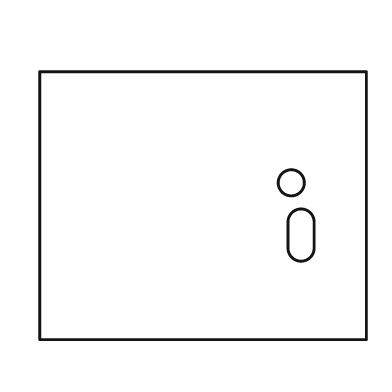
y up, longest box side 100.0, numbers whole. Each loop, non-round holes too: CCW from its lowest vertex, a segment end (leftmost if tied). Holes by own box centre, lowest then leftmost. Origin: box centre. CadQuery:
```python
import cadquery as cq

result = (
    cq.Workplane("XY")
    .moveTo(-50.0, -41.0)
    .lineTo(50.0, -41.0)
    .lineTo(50.0, 41.0)
    .lineTo(-50.0, 41.0)
    .close()
    .moveTo(26.0, -13.0)
    .threePointArc((30.0, -17.0), (34.0, -13.0))
    .lineTo(34.0, -5.0)
    .threePointArc((30.0, -1.0), (26.0, -5.0))
    .close()
    .moveTo(27.0, 7.0)
    .circle(4.0)
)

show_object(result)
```